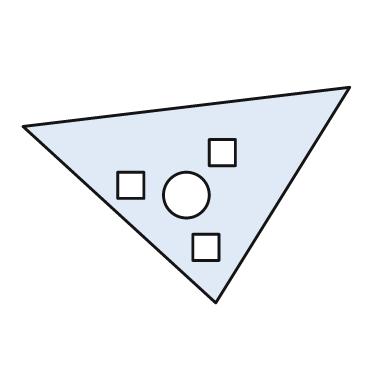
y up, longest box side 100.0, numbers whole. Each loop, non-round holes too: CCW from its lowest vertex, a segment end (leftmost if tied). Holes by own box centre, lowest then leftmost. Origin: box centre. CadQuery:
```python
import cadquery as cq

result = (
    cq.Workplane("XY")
    .moveTo(9.0, -33.0)
    .lineTo(50.0, 33.0)
    .lineTo(-50.0, 21.0)
    .close()
    .moveTo(2.0, -20.0)
    .lineTo(10.0, -20.0)
    .lineTo(10.0, -12.0)
    .lineTo(2.0, -12.0)
    .close()
    .moveTo(0.0, 0.0)
    .circle(7.0)
    .moveTo(-21.0, -1.0)
    .lineTo(-13.0, -1.0)
    .lineTo(-13.0, 7.0)
    .lineTo(-21.0, 7.0)
    .close()
    .moveTo(7.0, 9.0)
    .lineTo(15.0, 9.0)
    .lineTo(15.0, 17.0)
    .lineTo(7.0, 17.0)
    .close()
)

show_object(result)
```